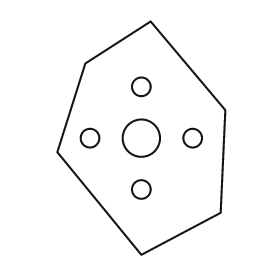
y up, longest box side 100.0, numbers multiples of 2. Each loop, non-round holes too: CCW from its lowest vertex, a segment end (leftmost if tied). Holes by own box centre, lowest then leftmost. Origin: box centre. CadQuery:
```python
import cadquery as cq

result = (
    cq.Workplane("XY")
    .moveTo(0.0, -50.0)
    .lineTo(34.0, -32.0)
    .lineTo(36.0, 12.0)
    .lineTo(4.0, 50.0)
    .lineTo(-24.0, 32.0)
    .lineTo(-36.0, -6.0)
    .close()
    .moveTo(0.0, -22.0)
    .circle(4.0)
    .moveTo(-22.0, 0.0)
    .circle(4.0)
    .moveTo(0.0, 0.0)
    .circle(8.0)
    .moveTo(22.0, 0.0)
    .circle(4.0)
    .moveTo(0.0, 22.0)
    .circle(4.0)
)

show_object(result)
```